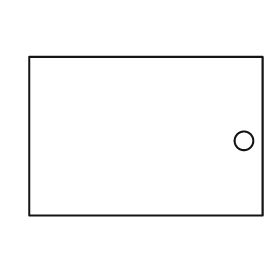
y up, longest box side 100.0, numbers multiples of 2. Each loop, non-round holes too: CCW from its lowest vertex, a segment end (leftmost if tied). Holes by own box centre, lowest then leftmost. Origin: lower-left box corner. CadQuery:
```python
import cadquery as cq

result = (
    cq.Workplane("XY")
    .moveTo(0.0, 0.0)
    .lineTo(100.0, 0.0)
    .lineTo(100.0, 68.0)
    .lineTo(0.0, 68.0)
    .close()
    .moveTo(92.0, 32.0)
    .circle(4.0)
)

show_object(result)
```